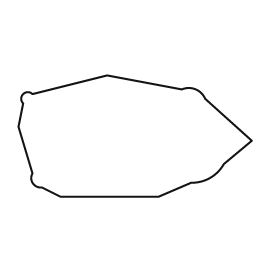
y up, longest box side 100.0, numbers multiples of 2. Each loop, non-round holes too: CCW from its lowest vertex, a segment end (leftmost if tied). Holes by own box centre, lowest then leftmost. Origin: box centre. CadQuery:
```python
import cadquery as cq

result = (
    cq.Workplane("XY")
    .moveTo(-32.0, -26.0)
    .lineTo(10.0, -26.0)
    .lineTo(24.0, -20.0)
    .threePointArc((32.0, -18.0), (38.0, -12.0))
    .lineTo(50.0, -2.0)
    .lineTo(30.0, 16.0)
    .threePointArc((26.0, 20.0), (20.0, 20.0))
    .lineTo(-12.0, 26.0)
    .lineTo(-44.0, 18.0)
    .threePointArc((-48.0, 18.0), (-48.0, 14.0))
    .lineTo(-50.0, 4.0)
    .lineTo(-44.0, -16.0)
    .threePointArc((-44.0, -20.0), (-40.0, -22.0))
    .close()
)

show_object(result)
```